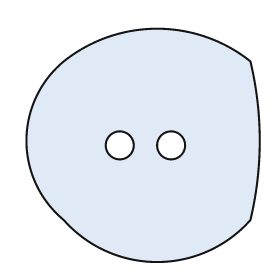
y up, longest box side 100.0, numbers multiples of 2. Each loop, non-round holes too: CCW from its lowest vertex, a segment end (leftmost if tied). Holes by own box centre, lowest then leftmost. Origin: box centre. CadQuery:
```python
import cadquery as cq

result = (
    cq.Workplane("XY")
    .moveTo(-34.0, -32.0)
    .threePointArc((6.0, -50.0), (46.0, -32.0))
    .threePointArc((50.0, 2.0), (46.0, 36.0))
    .threePointArc((6.0, 50.0), (-34.0, 36.0))
    .threePointArc((-50.0, 2.0), (-34.0, -32.0))
    .close()
    .moveTo(-10.0, 0.0)
    .circle(6.0)
    .moveTo(12.0, 0.0)
    .circle(6.0)
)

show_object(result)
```